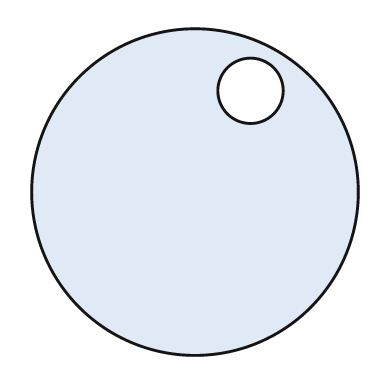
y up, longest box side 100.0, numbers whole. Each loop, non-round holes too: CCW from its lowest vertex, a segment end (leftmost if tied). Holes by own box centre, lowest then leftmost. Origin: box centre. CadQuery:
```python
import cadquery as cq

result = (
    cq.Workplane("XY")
    .moveTo(0.0, 0.0)
    .circle(50.0)
    .moveTo(17.0, 31.0)
    .circle(10.0)
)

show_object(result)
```